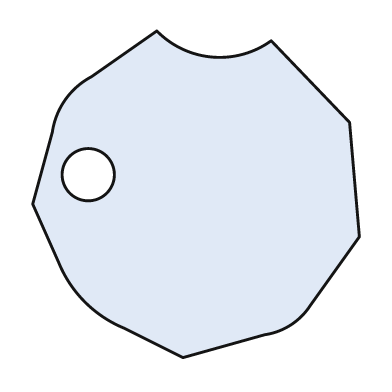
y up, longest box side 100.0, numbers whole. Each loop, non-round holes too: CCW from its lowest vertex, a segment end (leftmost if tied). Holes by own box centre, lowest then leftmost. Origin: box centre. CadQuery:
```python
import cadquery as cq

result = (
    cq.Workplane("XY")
    .moveTo(-4.0, -50.0)
    .lineTo(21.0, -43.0)
    .threePointArc((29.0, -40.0), (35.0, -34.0))
    .lineTo(50.0, -13.0)
    .lineTo(47.0, 22.0)
    .lineTo(23.0, 47.0)
    .threePointArc((5.0, 42.0), (-12.0, 50.0))
    .lineTo(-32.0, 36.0)
    .threePointArc((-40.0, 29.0), (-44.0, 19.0))
    .lineTo(-50.0, -3.0)
    .lineTo(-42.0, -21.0)
    .threePointArc((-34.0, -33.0), (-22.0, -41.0))
    .close()
    .moveTo(-33.0, 6.0)
    .circle(8.0)
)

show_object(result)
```